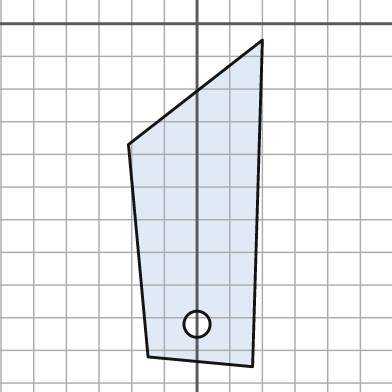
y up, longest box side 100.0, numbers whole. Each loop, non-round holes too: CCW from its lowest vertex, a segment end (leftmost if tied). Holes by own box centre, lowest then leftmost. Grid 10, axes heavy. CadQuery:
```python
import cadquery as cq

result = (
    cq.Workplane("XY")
    .moveTo(17.0, -105.0)
    .lineTo(20.0, -5.0)
    .lineTo(-21.0, -37.0)
    .lineTo(-15.0, -102.0)
    .close()
    .moveTo(0.0, -92.0)
    .circle(4.0)
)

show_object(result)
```